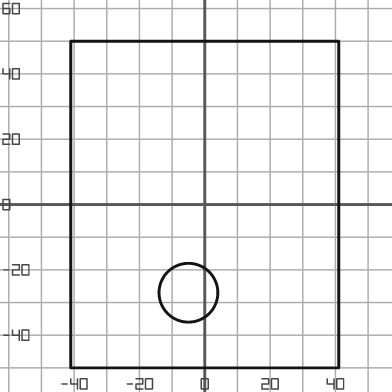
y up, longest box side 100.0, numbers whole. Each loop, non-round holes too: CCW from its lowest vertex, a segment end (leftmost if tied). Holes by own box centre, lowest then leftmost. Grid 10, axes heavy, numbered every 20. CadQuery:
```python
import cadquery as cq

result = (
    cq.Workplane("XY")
    .moveTo(-41.0, -50.0)
    .lineTo(41.0, -50.0)
    .lineTo(41.0, 50.0)
    .lineTo(-41.0, 50.0)
    .close()
    .moveTo(-5.0, -27.0)
    .circle(9.0)
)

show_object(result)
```